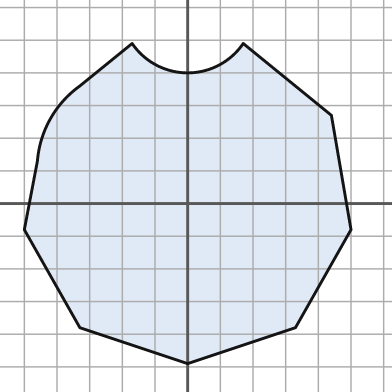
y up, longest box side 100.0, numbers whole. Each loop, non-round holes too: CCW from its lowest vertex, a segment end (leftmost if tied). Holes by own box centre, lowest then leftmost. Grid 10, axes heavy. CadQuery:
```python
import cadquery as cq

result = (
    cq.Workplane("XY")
    .moveTo(0.0, -49.0)
    .lineTo(33.0, -38.0)
    .lineTo(50.0, -8.0)
    .lineTo(44.0, 27.0)
    .lineTo(17.0, 49.0)
    .threePointArc((0.0, 40.0), (-17.0, 49.0))
    .lineTo(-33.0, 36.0)
    .threePointArc((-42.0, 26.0), (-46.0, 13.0))
    .lineTo(-50.0, -8.0)
    .lineTo(-33.0, -38.0)
    .close()
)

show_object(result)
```